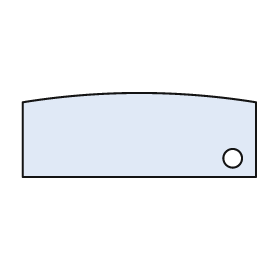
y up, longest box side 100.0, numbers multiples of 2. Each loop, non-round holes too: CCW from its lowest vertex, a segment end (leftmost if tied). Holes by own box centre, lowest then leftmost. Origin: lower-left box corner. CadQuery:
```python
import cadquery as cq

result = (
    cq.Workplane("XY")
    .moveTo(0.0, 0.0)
    .lineTo(100.0, 0.0)
    .lineTo(100.0, 32.0)
    .threePointArc((50.0, 36.0), (0.0, 32.0))
    .close()
    .moveTo(90.0, 8.0)
    .circle(4.0)
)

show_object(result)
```